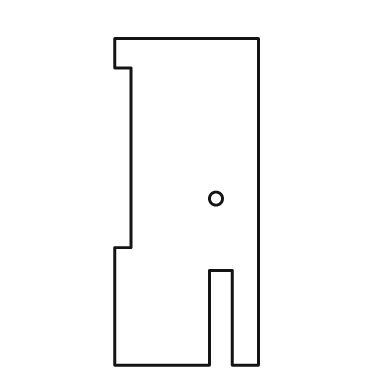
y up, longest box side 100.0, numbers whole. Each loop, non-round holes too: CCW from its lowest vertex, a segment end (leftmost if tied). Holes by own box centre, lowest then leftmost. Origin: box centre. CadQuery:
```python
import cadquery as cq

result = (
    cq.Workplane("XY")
    .moveTo(-22.0, -50.0)
    .lineTo(7.0, -50.0)
    .lineTo(7.0, -21.0)
    .lineTo(14.0, -21.0)
    .lineTo(14.0, -50.0)
    .lineTo(22.0, -50.0)
    .lineTo(22.0, 50.0)
    .lineTo(-22.0, 50.0)
    .lineTo(-22.0, 41.0)
    .lineTo(-17.0, 41.0)
    .lineTo(-17.0, -14.0)
    .lineTo(-22.0, -14.0)
    .close()
    .moveTo(9.0, 1.0)
    .circle(2.0)
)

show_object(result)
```